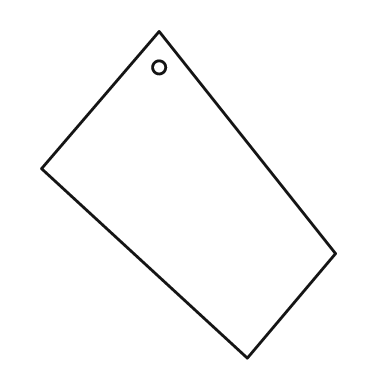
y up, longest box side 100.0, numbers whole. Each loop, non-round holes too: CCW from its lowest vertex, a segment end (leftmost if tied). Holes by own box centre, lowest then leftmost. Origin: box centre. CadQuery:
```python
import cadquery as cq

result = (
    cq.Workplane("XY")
    .moveTo(18.0, -50.0)
    .lineTo(45.0, -18.0)
    .lineTo(-9.0, 50.0)
    .lineTo(-45.0, 8.0)
    .close()
    .moveTo(-9.0, 39.0)
    .circle(2.0)
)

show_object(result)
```